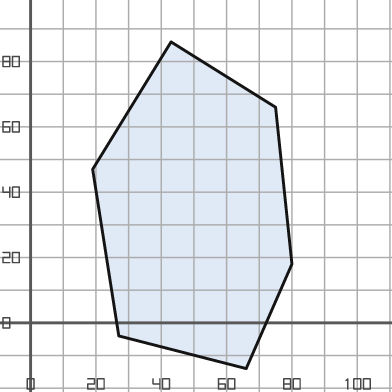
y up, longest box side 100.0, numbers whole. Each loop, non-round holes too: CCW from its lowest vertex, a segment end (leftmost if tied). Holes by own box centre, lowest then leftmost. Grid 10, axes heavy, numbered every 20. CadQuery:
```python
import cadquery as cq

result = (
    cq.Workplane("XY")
    .moveTo(66.0, -14.0)
    .lineTo(80.0, 18.0)
    .lineTo(75.0, 66.0)
    .lineTo(43.0, 86.0)
    .lineTo(19.0, 47.0)
    .lineTo(27.0, -4.0)
    .close()
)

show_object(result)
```